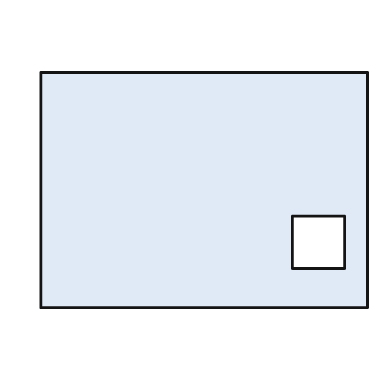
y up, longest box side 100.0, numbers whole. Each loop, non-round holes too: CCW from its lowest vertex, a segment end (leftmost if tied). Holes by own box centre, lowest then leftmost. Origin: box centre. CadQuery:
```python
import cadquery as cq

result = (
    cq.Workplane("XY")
    .moveTo(-50.0, -36.0)
    .lineTo(50.0, -36.0)
    .lineTo(50.0, 36.0)
    .lineTo(-50.0, 36.0)
    .close()
    .moveTo(27.0, -24.0)
    .lineTo(43.0, -24.0)
    .lineTo(43.0, -8.0)
    .lineTo(27.0, -8.0)
    .close()
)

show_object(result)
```